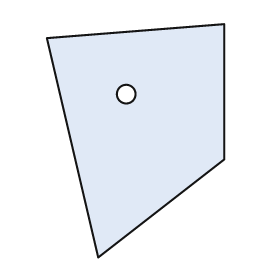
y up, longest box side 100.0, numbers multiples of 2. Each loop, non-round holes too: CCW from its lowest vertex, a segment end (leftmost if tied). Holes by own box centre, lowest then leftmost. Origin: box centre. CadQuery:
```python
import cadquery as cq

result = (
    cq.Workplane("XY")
    .moveTo(-16.0, -50.0)
    .lineTo(38.0, -8.0)
    .lineTo(38.0, 50.0)
    .lineTo(-38.0, 44.0)
    .close()
    .moveTo(-4.0, 20.0)
    .circle(4.0)
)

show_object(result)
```